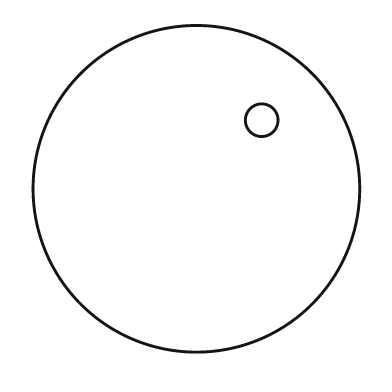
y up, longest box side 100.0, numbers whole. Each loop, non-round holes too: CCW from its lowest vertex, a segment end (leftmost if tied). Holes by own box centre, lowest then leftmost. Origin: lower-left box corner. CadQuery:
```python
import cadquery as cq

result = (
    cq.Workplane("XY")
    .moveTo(50.0, 50.0)
    .circle(50.0)
    .moveTo(70.0, 71.0)
    .circle(5.0)
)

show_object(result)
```